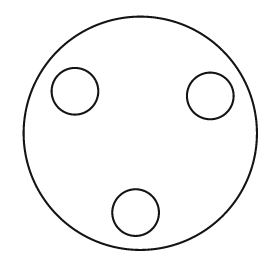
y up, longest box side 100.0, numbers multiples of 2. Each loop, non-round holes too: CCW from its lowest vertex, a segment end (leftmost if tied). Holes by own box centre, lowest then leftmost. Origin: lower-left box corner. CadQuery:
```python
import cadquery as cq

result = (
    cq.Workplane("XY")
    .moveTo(50.0, 50.0)
    .circle(50.0)
    .moveTo(48.0, 16.0)
    .circle(10.0)
    .moveTo(80.0, 66.0)
    .circle(10.0)
    .moveTo(22.0, 68.0)
    .circle(10.0)
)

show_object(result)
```